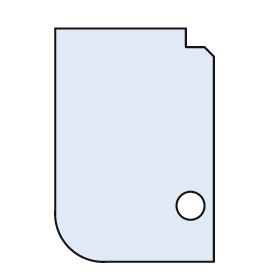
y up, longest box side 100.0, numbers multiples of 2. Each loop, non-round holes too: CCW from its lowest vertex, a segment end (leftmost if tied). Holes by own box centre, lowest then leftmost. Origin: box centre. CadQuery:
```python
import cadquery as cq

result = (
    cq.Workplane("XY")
    .moveTo(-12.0, -50.0)
    .lineTo(34.0, -50.0)
    .lineTo(34.0, 38.0)
    .lineTo(30.0, 42.0)
    .lineTo(22.0, 42.0)
    .lineTo(22.0, 50.0)
    .lineTo(-34.0, 50.0)
    .lineTo(-34.0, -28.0)
    .threePointArc((-28.0, -44.0), (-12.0, -50.0))
    .close()
    .moveTo(24.0, -26.0)
    .circle(6.0)
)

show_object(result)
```